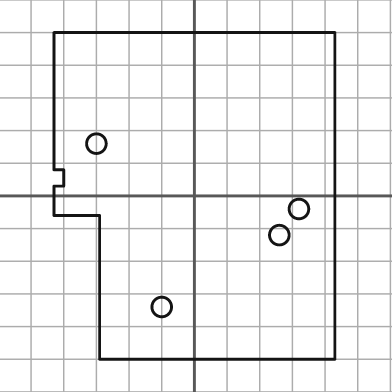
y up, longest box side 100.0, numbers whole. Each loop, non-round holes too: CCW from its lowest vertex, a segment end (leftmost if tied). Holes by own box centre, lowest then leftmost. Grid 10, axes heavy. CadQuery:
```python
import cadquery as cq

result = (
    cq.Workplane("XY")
    .moveTo(-29.0, -50.0)
    .lineTo(43.0, -50.0)
    .lineTo(43.0, 50.0)
    .lineTo(-43.0, 50.0)
    .lineTo(-43.0, 8.0)
    .lineTo(-40.0, 8.0)
    .lineTo(-40.0, 3.0)
    .lineTo(-43.0, 3.0)
    .lineTo(-43.0, -6.0)
    .lineTo(-29.0, -6.0)
    .close()
    .moveTo(-10.0, -34.0)
    .circle(3.0)
    .moveTo(26.0, -12.0)
    .circle(3.0)
    .moveTo(32.0, -4.0)
    .circle(3.0)
    .moveTo(-30.0, 16.0)
    .circle(3.0)
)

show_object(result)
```